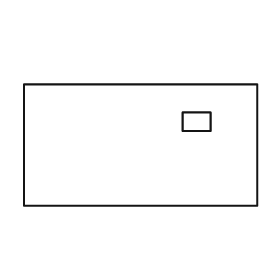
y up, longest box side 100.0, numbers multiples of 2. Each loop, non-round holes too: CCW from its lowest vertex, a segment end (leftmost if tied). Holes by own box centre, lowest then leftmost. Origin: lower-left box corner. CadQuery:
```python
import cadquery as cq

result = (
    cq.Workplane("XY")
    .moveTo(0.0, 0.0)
    .lineTo(100.0, 0.0)
    .lineTo(100.0, 52.0)
    .lineTo(0.0, 52.0)
    .close()
    .moveTo(68.0, 32.0)
    .lineTo(80.0, 32.0)
    .lineTo(80.0, 40.0)
    .lineTo(68.0, 40.0)
    .close()
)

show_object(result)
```